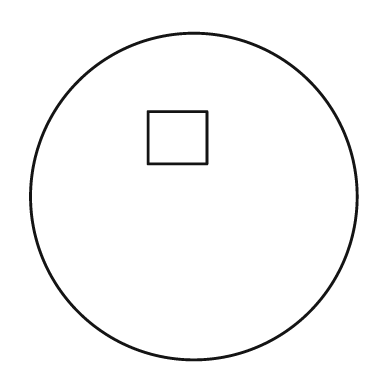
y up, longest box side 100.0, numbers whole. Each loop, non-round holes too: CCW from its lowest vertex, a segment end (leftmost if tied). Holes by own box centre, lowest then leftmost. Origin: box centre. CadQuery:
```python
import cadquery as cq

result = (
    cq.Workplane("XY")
    .moveTo(0.0, 0.0)
    .circle(50.0)
    .moveTo(-14.0, 10.0)
    .lineTo(4.0, 10.0)
    .lineTo(4.0, 26.0)
    .lineTo(-14.0, 26.0)
    .close()
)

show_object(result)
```